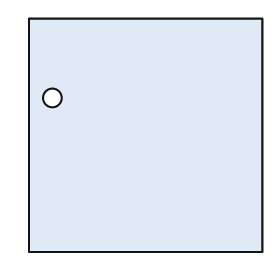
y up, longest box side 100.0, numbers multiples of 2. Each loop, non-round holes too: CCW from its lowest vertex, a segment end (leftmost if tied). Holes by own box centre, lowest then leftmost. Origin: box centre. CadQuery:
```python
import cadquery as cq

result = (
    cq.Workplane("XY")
    .moveTo(-50.0, -50.0)
    .lineTo(50.0, -50.0)
    .lineTo(50.0, 50.0)
    .lineTo(-50.0, 50.0)
    .close()
    .moveTo(-40.0, 16.0)
    .circle(4.0)
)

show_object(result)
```